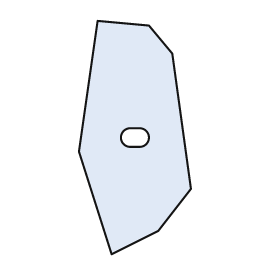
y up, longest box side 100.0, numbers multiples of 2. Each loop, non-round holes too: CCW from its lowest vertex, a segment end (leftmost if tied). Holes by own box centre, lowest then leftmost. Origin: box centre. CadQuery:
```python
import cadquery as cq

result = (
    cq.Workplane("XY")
    .moveTo(-10.0, -50.0)
    .lineTo(10.0, -40.0)
    .lineTo(24.0, -22.0)
    .lineTo(16.0, 36.0)
    .lineTo(6.0, 48.0)
    .lineTo(-16.0, 50.0)
    .lineTo(-24.0, -6.0)
    .close()
    .moveTo(-2.0, -4.0)
    .lineTo(2.0, -4.0)
    .threePointArc((6.0, 0.0), (2.0, 4.0))
    .lineTo(-2.0, 4.0)
    .threePointArc((-6.0, 0.0), (-2.0, -4.0))
    .close()
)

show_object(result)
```